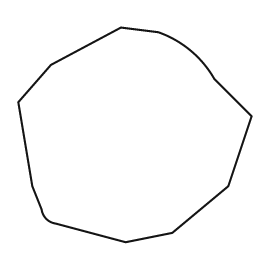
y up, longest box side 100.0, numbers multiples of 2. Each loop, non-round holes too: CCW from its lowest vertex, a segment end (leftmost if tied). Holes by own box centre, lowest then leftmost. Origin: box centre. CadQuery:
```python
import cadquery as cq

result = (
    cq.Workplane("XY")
    .moveTo(-4.0, -46.0)
    .lineTo(16.0, -42.0)
    .lineTo(40.0, -22.0)
    .lineTo(50.0, 8.0)
    .lineTo(34.0, 24.0)
    .threePointArc((24.0, 36.0), (10.0, 44.0))
    .lineTo(-6.0, 46.0)
    .lineTo(-36.0, 30.0)
    .lineTo(-50.0, 14.0)
    .lineTo(-44.0, -22.0)
    .lineTo(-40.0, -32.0)
    .threePointArc((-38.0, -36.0), (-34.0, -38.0))
    .close()
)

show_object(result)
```